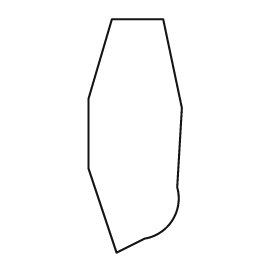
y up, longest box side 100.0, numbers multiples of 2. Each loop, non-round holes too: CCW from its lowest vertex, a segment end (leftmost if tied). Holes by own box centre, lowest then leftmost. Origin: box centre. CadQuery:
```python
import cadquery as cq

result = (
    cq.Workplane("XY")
    .moveTo(-8.0, -50.0)
    .lineTo(4.0, -44.0)
    .threePointArc((16.0, -36.0), (18.0, -22.0))
    .lineTo(20.0, 12.0)
    .lineTo(12.0, 50.0)
    .lineTo(-10.0, 50.0)
    .lineTo(-20.0, 16.0)
    .lineTo(-20.0, -14.0)
    .close()
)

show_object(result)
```